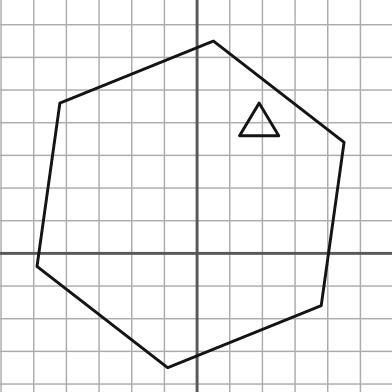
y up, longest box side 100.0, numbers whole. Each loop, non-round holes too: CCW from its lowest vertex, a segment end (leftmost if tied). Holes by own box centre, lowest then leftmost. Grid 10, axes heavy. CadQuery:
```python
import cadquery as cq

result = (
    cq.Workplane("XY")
    .moveTo(-9.0, -35.0)
    .lineTo(38.0, -16.0)
    .lineTo(45.0, 34.0)
    .lineTo(5.0, 65.0)
    .lineTo(-42.0, 46.0)
    .lineTo(-49.0, -4.0)
    .close()
    .moveTo(13.0, 36.0)
    .lineTo(25.0, 36.0)
    .lineTo(19.0, 46.0)
    .close()
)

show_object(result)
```